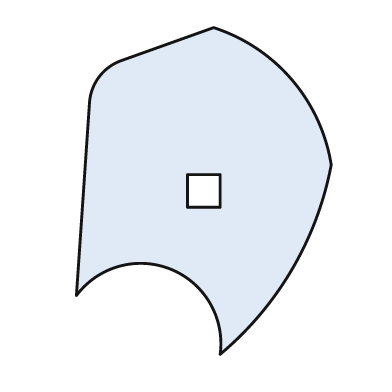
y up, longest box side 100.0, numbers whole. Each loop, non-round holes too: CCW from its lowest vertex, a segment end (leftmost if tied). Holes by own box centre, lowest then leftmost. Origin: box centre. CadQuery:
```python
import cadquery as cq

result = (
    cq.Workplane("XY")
    .moveTo(5.0, -50.0)
    .threePointArc((27.0, -24.0), (39.0, 8.0))
    .threePointArc((27.0, 34.0), (3.0, 50.0))
    .lineTo(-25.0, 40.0)
    .threePointArc((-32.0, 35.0), (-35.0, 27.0))
    .lineTo(-39.0, -32.0)
    .threePointArc((-10.0, -24.0), (5.0, -50.0))
    .close()
    .moveTo(-5.0, -5.0)
    .lineTo(5.0, -5.0)
    .lineTo(5.0, 5.0)
    .lineTo(-5.0, 5.0)
    .close()
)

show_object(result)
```